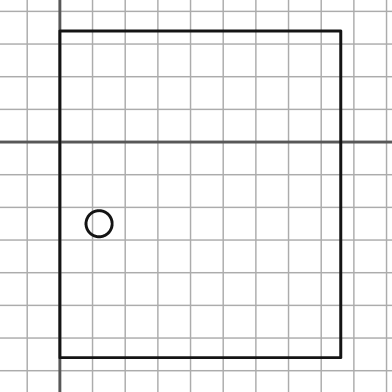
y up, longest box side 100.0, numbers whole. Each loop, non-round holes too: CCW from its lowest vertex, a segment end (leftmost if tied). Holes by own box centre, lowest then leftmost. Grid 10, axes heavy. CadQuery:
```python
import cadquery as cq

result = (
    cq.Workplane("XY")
    .moveTo(0.0, -66.0)
    .lineTo(86.0, -66.0)
    .lineTo(86.0, 34.0)
    .lineTo(0.0, 34.0)
    .close()
    .moveTo(12.0, -25.0)
    .circle(4.0)
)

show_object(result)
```